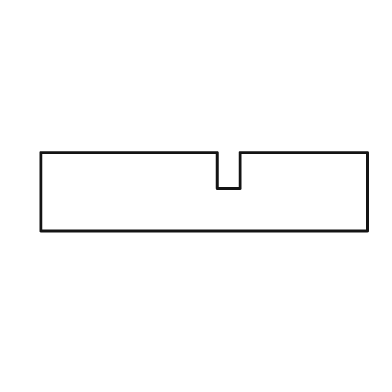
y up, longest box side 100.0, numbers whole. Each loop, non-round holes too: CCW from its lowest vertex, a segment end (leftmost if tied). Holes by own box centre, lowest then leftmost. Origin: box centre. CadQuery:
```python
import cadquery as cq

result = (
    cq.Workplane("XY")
    .moveTo(-50.0, -12.0)
    .lineTo(50.0, -12.0)
    .lineTo(50.0, 12.0)
    .lineTo(11.0, 12.0)
    .lineTo(11.0, 1.0)
    .lineTo(4.0, 1.0)
    .lineTo(4.0, 12.0)
    .lineTo(-50.0, 12.0)
    .close()
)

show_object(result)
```